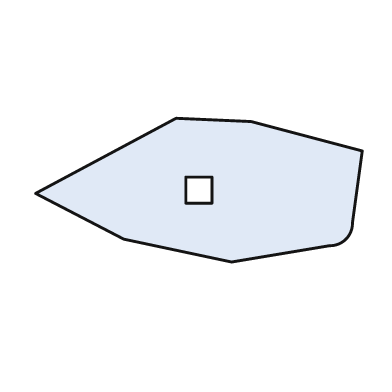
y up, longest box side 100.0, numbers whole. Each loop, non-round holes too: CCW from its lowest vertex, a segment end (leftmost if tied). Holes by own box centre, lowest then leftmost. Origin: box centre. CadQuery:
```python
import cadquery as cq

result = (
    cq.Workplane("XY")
    .moveTo(10.0, -22.0)
    .lineTo(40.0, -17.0)
    .threePointArc((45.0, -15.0), (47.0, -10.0))
    .lineTo(50.0, 12.0)
    .lineTo(16.0, 21.0)
    .lineTo(-7.0, 22.0)
    .lineTo(-50.0, -1.0)
    .lineTo(-23.0, -15.0)
    .close()
    .moveTo(-4.0, -4.0)
    .lineTo(4.0, -4.0)
    .lineTo(4.0, 4.0)
    .lineTo(-4.0, 4.0)
    .close()
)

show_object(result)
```